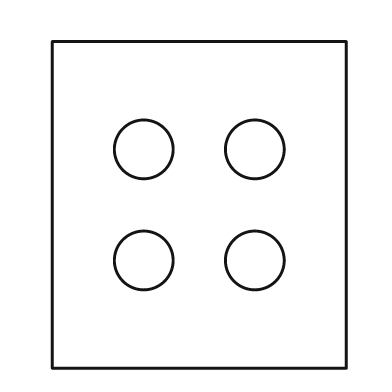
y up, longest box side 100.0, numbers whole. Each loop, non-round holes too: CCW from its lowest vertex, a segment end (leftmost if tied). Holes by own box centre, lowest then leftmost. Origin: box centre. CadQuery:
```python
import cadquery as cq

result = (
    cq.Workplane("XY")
    .moveTo(-45.0, -50.0)
    .lineTo(45.0, -50.0)
    .lineTo(45.0, 50.0)
    .lineTo(-45.0, 50.0)
    .close()
    .moveTo(-17.0, -17.0)
    .circle(9.0)
    .moveTo(17.0, -17.0)
    .circle(9.0)
    .moveTo(-17.0, 17.0)
    .circle(9.0)
    .moveTo(17.0, 17.0)
    .circle(9.0)
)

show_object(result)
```